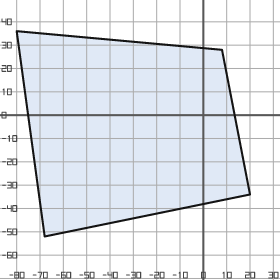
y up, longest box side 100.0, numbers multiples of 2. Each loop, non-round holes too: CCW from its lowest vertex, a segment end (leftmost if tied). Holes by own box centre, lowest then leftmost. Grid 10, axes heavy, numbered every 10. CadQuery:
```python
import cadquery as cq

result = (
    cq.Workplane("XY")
    .moveTo(-68.0, -52.0)
    .lineTo(20.0, -34.0)
    .lineTo(8.0, 28.0)
    .lineTo(-80.0, 36.0)
    .close()
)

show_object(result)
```